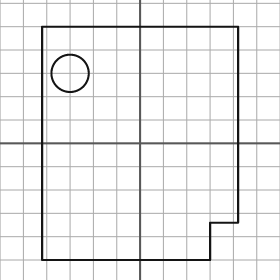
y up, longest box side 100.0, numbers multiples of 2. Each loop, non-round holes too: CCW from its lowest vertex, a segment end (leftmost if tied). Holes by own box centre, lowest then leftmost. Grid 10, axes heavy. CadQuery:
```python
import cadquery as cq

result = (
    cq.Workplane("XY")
    .moveTo(-42.0, -50.0)
    .lineTo(30.0, -50.0)
    .lineTo(30.0, -34.0)
    .lineTo(42.0, -34.0)
    .lineTo(42.0, 50.0)
    .lineTo(-42.0, 50.0)
    .close()
    .moveTo(-30.0, 30.0)
    .circle(8.0)
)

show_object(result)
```